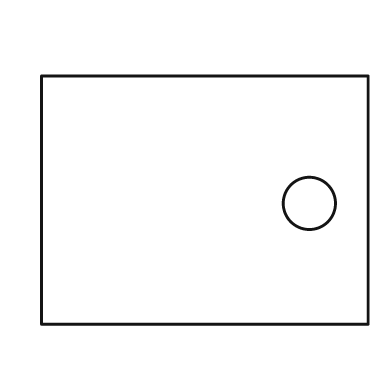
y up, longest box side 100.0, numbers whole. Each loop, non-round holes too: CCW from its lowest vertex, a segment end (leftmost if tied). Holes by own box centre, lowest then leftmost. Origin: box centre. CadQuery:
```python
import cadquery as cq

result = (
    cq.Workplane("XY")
    .moveTo(-50.0, -38.0)
    .lineTo(50.0, -38.0)
    .lineTo(50.0, 38.0)
    .lineTo(-50.0, 38.0)
    .close()
    .moveTo(32.0, -1.0)
    .circle(8.0)
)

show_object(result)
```